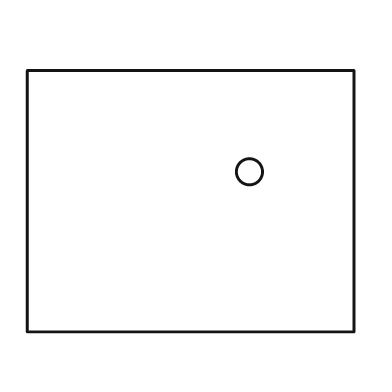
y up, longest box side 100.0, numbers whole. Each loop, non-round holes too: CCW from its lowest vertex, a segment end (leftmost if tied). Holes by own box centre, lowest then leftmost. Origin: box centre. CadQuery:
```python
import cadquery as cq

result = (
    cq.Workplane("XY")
    .moveTo(-50.0, -40.0)
    .lineTo(50.0, -40.0)
    .lineTo(50.0, 40.0)
    .lineTo(-50.0, 40.0)
    .close()
    .moveTo(18.0, 9.0)
    .circle(4.0)
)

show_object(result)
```